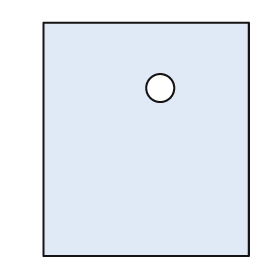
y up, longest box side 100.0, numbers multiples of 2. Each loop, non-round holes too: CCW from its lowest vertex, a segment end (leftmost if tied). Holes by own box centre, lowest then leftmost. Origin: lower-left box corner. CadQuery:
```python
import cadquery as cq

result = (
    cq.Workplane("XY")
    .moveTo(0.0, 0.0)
    .lineTo(88.0, 0.0)
    .lineTo(88.0, 100.0)
    .lineTo(0.0, 100.0)
    .close()
    .moveTo(50.0, 72.0)
    .circle(6.0)
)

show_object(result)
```